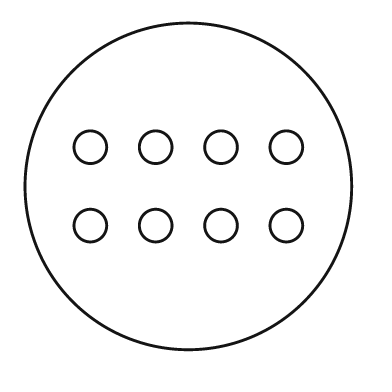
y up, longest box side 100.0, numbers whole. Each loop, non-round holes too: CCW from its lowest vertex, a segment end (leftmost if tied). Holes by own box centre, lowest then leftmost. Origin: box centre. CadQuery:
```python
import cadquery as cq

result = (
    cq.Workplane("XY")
    .moveTo(0.0, 0.0)
    .circle(50.0)
    .moveTo(-30.0, -12.0)
    .circle(5.0)
    .moveTo(-10.0, -12.0)
    .circle(5.0)
    .moveTo(10.0, -12.0)
    .circle(5.0)
    .moveTo(30.0, -12.0)
    .circle(5.0)
    .moveTo(-30.0, 12.0)
    .circle(5.0)
    .moveTo(-10.0, 12.0)
    .circle(5.0)
    .moveTo(10.0, 12.0)
    .circle(5.0)
    .moveTo(30.0, 12.0)
    .circle(5.0)
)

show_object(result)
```